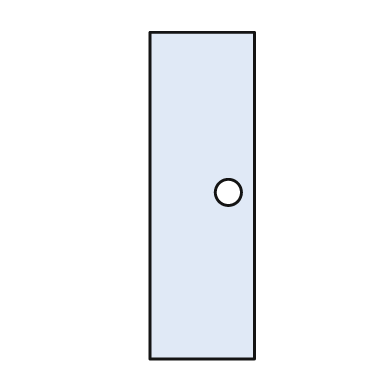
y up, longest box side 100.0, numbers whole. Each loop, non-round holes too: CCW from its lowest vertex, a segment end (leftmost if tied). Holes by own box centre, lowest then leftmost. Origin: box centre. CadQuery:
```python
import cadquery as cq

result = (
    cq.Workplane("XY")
    .moveTo(-16.0, -50.0)
    .lineTo(16.0, -50.0)
    .lineTo(16.0, 50.0)
    .lineTo(-16.0, 50.0)
    .close()
    .moveTo(8.0, 1.0)
    .circle(4.0)
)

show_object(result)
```